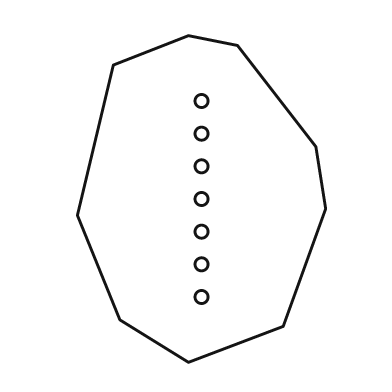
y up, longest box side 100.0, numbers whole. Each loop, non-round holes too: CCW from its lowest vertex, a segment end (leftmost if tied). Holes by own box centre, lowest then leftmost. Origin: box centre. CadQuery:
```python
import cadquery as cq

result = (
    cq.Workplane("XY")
    .moveTo(-4.0, -50.0)
    .lineTo(25.0, -39.0)
    .lineTo(38.0, -3.0)
    .lineTo(35.0, 16.0)
    .lineTo(11.0, 47.0)
    .lineTo(-4.0, 50.0)
    .lineTo(-27.0, 41.0)
    .lineTo(-38.0, -5.0)
    .lineTo(-25.0, -37.0)
    .close()
    .moveTo(0.0, -30.0)
    .circle(2.0)
    .moveTo(0.0, -20.0)
    .circle(2.0)
    .moveTo(0.0, -10.0)
    .circle(2.0)
    .moveTo(0.0, 0.0)
    .circle(2.0)
    .moveTo(0.0, 10.0)
    .circle(2.0)
    .moveTo(0.0, 20.0)
    .circle(2.0)
    .moveTo(0.0, 30.0)
    .circle(2.0)
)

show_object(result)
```